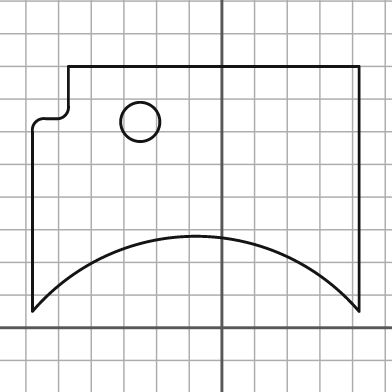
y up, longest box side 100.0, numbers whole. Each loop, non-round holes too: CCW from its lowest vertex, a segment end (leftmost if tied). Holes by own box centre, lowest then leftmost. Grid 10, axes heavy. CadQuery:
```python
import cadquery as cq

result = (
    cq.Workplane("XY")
    .moveTo(-58.0, 5.0)
    .threePointArc((-8.0, 28.0), (42.0, 5.0))
    .lineTo(42.0, 80.0)
    .lineTo(-47.0, 80.0)
    .lineTo(-47.0, 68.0)
    .threePointArc((-48.0, 65.0), (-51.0, 64.0))
    .lineTo(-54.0, 64.0)
    .threePointArc((-57.0, 63.0), (-58.0, 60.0))
    .close()
    .moveTo(-25.0, 63.0)
    .circle(6.0)
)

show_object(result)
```